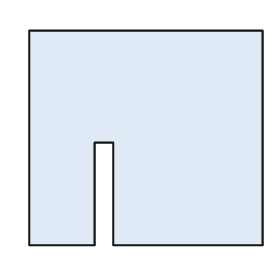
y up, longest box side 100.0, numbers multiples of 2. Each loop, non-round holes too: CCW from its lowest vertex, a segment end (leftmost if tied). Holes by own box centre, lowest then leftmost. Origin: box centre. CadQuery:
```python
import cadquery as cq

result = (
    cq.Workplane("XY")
    .moveTo(-50.0, -46.0)
    .lineTo(-22.0, -46.0)
    .lineTo(-22.0, -2.0)
    .lineTo(-14.0, -2.0)
    .lineTo(-14.0, -46.0)
    .lineTo(50.0, -46.0)
    .lineTo(50.0, 46.0)
    .lineTo(-50.0, 46.0)
    .close()
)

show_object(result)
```